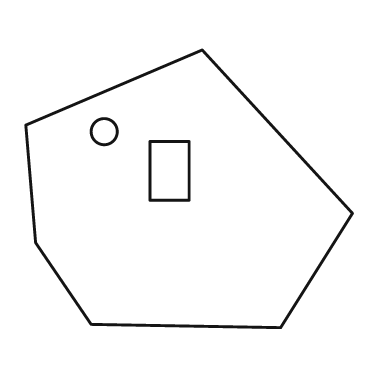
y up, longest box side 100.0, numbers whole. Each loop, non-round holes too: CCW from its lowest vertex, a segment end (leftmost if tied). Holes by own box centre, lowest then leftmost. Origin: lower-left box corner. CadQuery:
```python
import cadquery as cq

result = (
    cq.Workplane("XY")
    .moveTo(78.0, 0.0)
    .lineTo(100.0, 35.0)
    .lineTo(54.0, 85.0)
    .lineTo(0.0, 62.0)
    .lineTo(3.0, 26.0)
    .lineTo(20.0, 1.0)
    .close()
    .moveTo(38.0, 39.0)
    .lineTo(50.0, 39.0)
    .lineTo(50.0, 57.0)
    .lineTo(38.0, 57.0)
    .close()
    .moveTo(24.0, 60.0)
    .circle(4.0)
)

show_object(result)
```